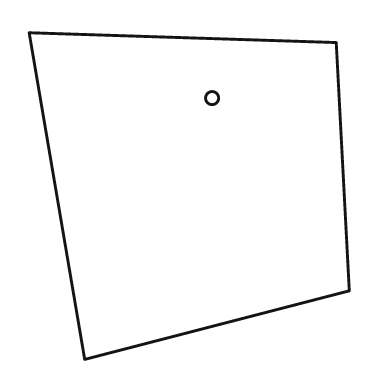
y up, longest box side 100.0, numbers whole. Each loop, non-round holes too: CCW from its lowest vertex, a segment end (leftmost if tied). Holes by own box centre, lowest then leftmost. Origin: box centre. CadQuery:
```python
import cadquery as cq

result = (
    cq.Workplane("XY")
    .moveTo(-32.0, -50.0)
    .lineTo(49.0, -29.0)
    .lineTo(45.0, 47.0)
    .lineTo(-49.0, 50.0)
    .close()
    .moveTo(7.0, 30.0)
    .circle(2.0)
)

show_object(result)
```